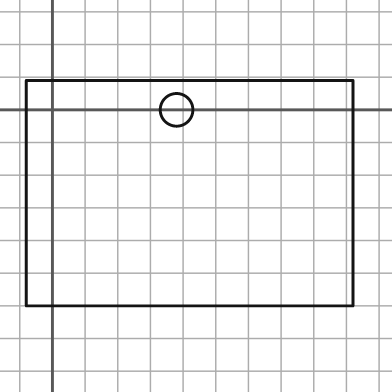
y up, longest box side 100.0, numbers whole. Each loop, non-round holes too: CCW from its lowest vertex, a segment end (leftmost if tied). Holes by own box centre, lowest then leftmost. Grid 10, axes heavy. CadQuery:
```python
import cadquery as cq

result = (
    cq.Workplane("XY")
    .moveTo(-8.0, -60.0)
    .lineTo(92.0, -60.0)
    .lineTo(92.0, 9.0)
    .lineTo(-8.0, 9.0)
    .close()
    .moveTo(38.0, 0.0)
    .circle(5.0)
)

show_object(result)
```